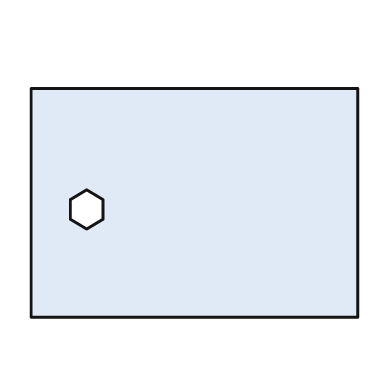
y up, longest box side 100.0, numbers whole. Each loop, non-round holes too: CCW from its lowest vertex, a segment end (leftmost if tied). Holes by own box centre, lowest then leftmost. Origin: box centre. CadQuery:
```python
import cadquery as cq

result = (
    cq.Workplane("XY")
    .moveTo(-50.0, -35.0)
    .lineTo(50.0, -35.0)
    .lineTo(50.0, 35.0)
    .lineTo(-50.0, 35.0)
    .close()
    .moveTo(-33.0, -8.0)
    .lineTo(-28.0, -5.0)
    .lineTo(-28.0, 1.0)
    .lineTo(-33.0, 4.0)
    .lineTo(-38.0, 1.0)
    .lineTo(-38.0, -5.0)
    .close()
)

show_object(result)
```